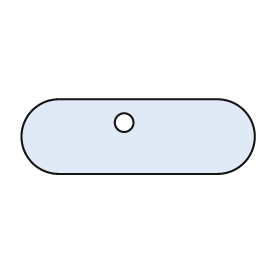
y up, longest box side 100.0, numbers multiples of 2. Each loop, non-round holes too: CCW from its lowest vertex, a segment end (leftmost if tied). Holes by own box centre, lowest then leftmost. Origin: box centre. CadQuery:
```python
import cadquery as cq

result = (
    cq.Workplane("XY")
    .moveTo(-34.0, -16.0)
    .lineTo(34.0, -16.0)
    .threePointArc((50.0, 0.0), (34.0, 16.0))
    .lineTo(-34.0, 16.0)
    .threePointArc((-50.0, 0.0), (-34.0, -16.0))
    .close()
    .moveTo(-6.0, 6.0)
    .circle(4.0)
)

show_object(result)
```